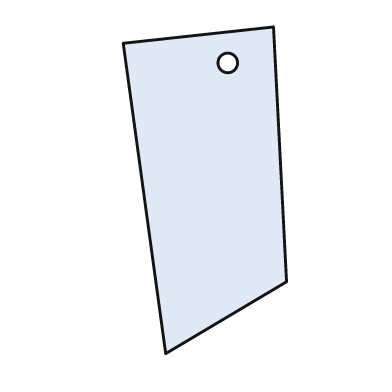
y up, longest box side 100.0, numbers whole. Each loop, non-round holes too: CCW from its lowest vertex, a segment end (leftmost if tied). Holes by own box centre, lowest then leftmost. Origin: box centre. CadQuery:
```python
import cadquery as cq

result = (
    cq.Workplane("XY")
    .moveTo(-12.0, -50.0)
    .lineTo(25.0, -28.0)
    .lineTo(21.0, 50.0)
    .lineTo(-25.0, 45.0)
    .close()
    .moveTo(7.0, 39.0)
    .circle(3.0)
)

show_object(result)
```